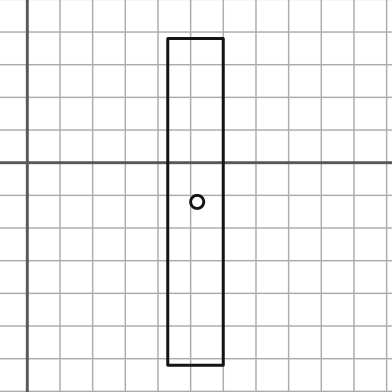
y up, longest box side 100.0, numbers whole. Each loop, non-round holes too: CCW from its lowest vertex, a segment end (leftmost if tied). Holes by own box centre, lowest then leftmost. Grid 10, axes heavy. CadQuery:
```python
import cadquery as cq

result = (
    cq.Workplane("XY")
    .moveTo(43.0, -62.0)
    .lineTo(60.0, -62.0)
    .lineTo(60.0, 38.0)
    .lineTo(43.0, 38.0)
    .close()
    .moveTo(52.0, -12.0)
    .circle(2.0)
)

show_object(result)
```